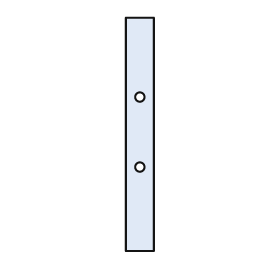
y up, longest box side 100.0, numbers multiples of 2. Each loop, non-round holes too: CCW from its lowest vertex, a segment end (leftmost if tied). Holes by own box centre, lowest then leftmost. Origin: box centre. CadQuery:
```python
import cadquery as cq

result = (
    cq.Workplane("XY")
    .moveTo(-6.0, -50.0)
    .lineTo(6.0, -50.0)
    .lineTo(6.0, 50.0)
    .lineTo(-6.0, 50.0)
    .close()
    .moveTo(0.0, -14.0)
    .circle(2.0)
    .moveTo(0.0, 16.0)
    .circle(2.0)
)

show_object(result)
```